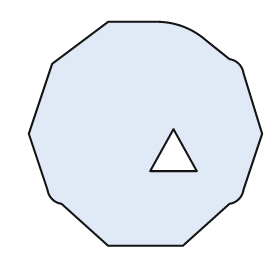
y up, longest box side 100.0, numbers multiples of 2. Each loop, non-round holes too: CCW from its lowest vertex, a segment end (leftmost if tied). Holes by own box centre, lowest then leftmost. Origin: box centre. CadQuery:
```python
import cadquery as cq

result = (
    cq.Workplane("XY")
    .moveTo(-16.0, -48.0)
    .lineTo(16.0, -48.0)
    .lineTo(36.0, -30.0)
    .threePointArc((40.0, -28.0), (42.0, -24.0))
    .lineTo(50.0, 0.0)
    .lineTo(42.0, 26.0)
    .threePointArc((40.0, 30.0), (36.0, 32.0))
    .lineTo(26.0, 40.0)
    .threePointArc((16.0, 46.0), (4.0, 48.0))
    .lineTo(-16.0, 48.0)
    .lineTo(-40.0, 30.0)
    .lineTo(-50.0, 0.0)
    .lineTo(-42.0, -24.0)
    .threePointArc((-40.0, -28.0), (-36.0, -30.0))
    .close()
    .moveTo(2.0, -16.0)
    .lineTo(22.0, -16.0)
    .lineTo(12.0, 2.0)
    .close()
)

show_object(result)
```